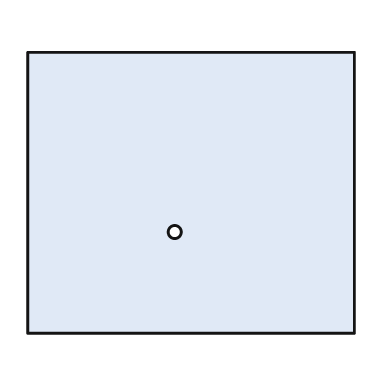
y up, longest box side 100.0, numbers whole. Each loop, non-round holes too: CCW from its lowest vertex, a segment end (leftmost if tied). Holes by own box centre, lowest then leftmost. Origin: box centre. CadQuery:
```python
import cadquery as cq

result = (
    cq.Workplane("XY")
    .moveTo(-50.0, -43.0)
    .lineTo(50.0, -43.0)
    .lineTo(50.0, 43.0)
    .lineTo(-50.0, 43.0)
    .close()
    .moveTo(-5.0, -12.0)
    .circle(2.0)
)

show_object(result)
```